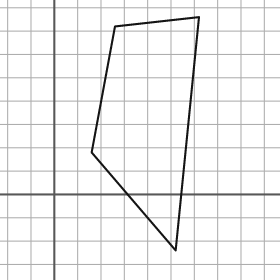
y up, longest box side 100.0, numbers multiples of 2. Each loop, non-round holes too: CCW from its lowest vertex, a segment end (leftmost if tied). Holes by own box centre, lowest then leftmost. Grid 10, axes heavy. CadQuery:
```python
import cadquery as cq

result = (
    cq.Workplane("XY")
    .moveTo(52.0, -24.0)
    .lineTo(62.0, 76.0)
    .lineTo(26.0, 72.0)
    .lineTo(16.0, 18.0)
    .close()
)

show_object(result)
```